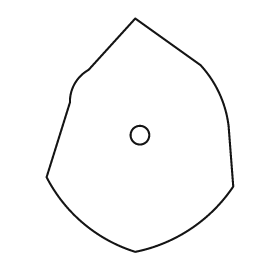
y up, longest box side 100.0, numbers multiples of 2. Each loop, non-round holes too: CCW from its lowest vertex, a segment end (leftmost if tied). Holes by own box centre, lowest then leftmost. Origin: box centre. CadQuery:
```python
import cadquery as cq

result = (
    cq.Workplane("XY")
    .moveTo(-2.0, -50.0)
    .threePointArc((22.0, -40.0), (40.0, -22.0))
    .lineTo(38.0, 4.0)
    .threePointArc((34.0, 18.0), (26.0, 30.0))
    .lineTo(-2.0, 50.0)
    .lineTo(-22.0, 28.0)
    .threePointArc((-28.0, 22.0), (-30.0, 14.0))
    .lineTo(-40.0, -18.0)
    .threePointArc((-24.0, -38.0), (-2.0, -50.0))
    .close()
    .moveTo(0.0, 0.0)
    .circle(4.0)
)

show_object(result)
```